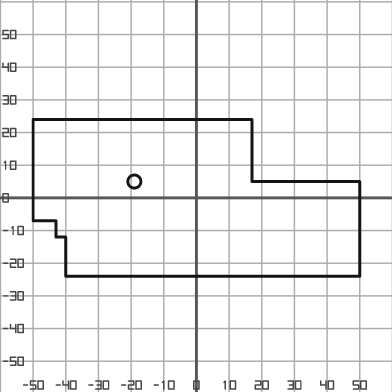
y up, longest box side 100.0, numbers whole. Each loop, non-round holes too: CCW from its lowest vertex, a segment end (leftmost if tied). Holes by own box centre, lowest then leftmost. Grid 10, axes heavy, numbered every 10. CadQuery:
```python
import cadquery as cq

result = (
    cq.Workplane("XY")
    .moveTo(-40.0, -24.0)
    .lineTo(50.0, -24.0)
    .lineTo(50.0, 5.0)
    .lineTo(17.0, 5.0)
    .lineTo(17.0, 24.0)
    .lineTo(-50.0, 24.0)
    .lineTo(-50.0, -7.0)
    .lineTo(-43.0, -7.0)
    .lineTo(-43.0, -12.0)
    .lineTo(-40.0, -12.0)
    .close()
    .moveTo(-19.0, 5.0)
    .circle(2.0)
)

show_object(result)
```